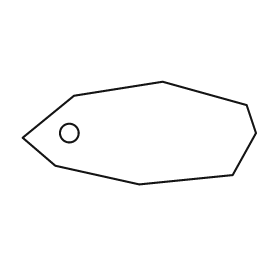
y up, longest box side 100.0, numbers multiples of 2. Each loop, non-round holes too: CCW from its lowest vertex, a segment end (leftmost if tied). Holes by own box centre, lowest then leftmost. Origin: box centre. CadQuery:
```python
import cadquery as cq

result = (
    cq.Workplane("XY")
    .moveTo(0.0, -22.0)
    .lineTo(40.0, -18.0)
    .lineTo(50.0, 0.0)
    .lineTo(46.0, 12.0)
    .lineTo(10.0, 22.0)
    .lineTo(-28.0, 16.0)
    .lineTo(-50.0, -2.0)
    .lineTo(-36.0, -14.0)
    .close()
    .moveTo(-30.0, 0.0)
    .circle(4.0)
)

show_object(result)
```